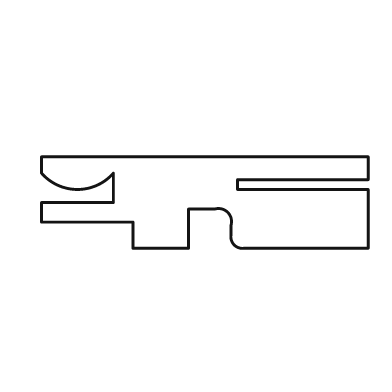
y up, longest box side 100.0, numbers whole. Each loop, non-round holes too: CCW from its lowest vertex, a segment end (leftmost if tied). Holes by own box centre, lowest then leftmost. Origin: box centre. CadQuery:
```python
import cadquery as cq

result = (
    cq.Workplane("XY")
    .moveTo(-22.0, -14.0)
    .lineTo(-5.0, -14.0)
    .lineTo(-5.0, -2.0)
    .lineTo(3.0, -2.0)
    .threePointArc((7.0, -3.0), (8.0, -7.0))
    .lineTo(8.0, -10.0)
    .threePointArc((9.0, -13.0), (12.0, -14.0))
    .lineTo(50.0, -14.0)
    .lineTo(50.0, 4.0)
    .lineTo(10.0, 4.0)
    .lineTo(10.0, 7.0)
    .lineTo(50.0, 7.0)
    .lineTo(50.0, 14.0)
    .lineTo(-50.0, 14.0)
    .lineTo(-50.0, 9.0)
    .threePointArc((-39.0, 4.0), (-28.0, 9.0))
    .lineTo(-28.0, 0.0)
    .lineTo(-50.0, 0.0)
    .lineTo(-50.0, -6.0)
    .lineTo(-22.0, -6.0)
    .close()
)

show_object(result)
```